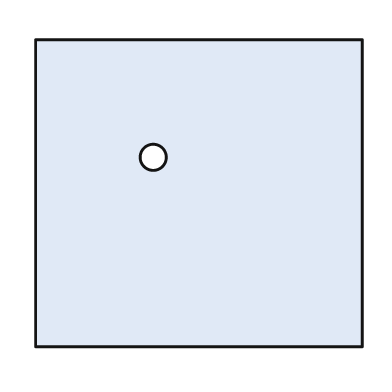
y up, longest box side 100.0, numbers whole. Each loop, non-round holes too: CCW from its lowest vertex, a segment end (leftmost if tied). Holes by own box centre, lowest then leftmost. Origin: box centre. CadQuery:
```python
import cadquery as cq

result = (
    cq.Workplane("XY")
    .moveTo(-50.0, -47.0)
    .lineTo(50.0, -47.0)
    .lineTo(50.0, 47.0)
    .lineTo(-50.0, 47.0)
    .close()
    .moveTo(-14.0, 11.0)
    .circle(4.0)
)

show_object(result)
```